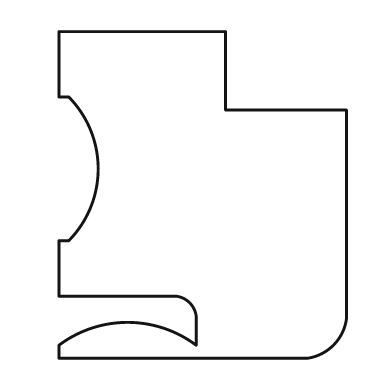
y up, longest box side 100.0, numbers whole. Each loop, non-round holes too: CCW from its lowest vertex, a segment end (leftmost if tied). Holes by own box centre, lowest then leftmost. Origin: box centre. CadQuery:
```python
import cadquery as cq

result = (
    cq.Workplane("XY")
    .moveTo(-44.0, -50.0)
    .lineTo(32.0, -50.0)
    .threePointArc((40.0, -46.0), (44.0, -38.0))
    .lineTo(44.0, 26.0)
    .lineTo(7.0, 26.0)
    .lineTo(7.0, 50.0)
    .lineTo(-44.0, 50.0)
    .lineTo(-44.0, 30.0)
    .lineTo(-41.0, 30.0)
    .threePointArc((-32.0, 8.0), (-41.0, -14.0))
    .lineTo(-44.0, -14.0)
    .lineTo(-44.0, -31.0)
    .lineTo(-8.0, -31.0)
    .threePointArc((-4.0, -33.0), (-2.0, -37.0))
    .lineTo(-2.0, -46.0)
    .threePointArc((-23.0, -39.0), (-44.0, -46.0))
    .close()
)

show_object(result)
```